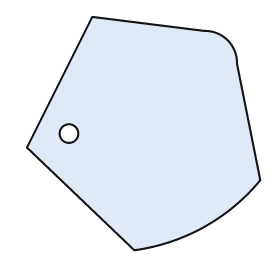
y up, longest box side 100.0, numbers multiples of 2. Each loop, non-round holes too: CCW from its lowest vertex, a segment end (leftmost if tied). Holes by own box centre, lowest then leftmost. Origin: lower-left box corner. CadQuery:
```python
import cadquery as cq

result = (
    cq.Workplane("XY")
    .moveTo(46.0, 0.0)
    .threePointArc((76.0, 10.0), (100.0, 30.0))
    .lineTo(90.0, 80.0)
    .threePointArc((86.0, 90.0), (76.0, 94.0))
    .lineTo(28.0, 100.0)
    .lineTo(0.0, 44.0)
    .close()
    .moveTo(18.0, 50.0)
    .circle(4.0)
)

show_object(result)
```